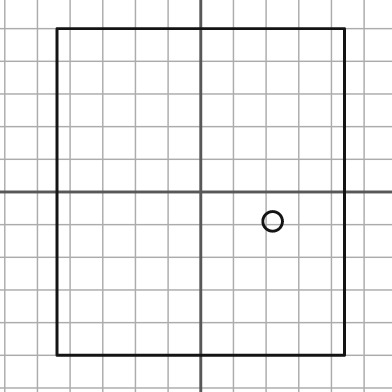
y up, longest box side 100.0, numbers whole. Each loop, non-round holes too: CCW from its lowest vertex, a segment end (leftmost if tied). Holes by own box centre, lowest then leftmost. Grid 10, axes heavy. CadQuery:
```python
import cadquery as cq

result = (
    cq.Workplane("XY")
    .moveTo(-44.0, -50.0)
    .lineTo(44.0, -50.0)
    .lineTo(44.0, 50.0)
    .lineTo(-44.0, 50.0)
    .close()
    .moveTo(22.0, -9.0)
    .circle(3.0)
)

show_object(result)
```